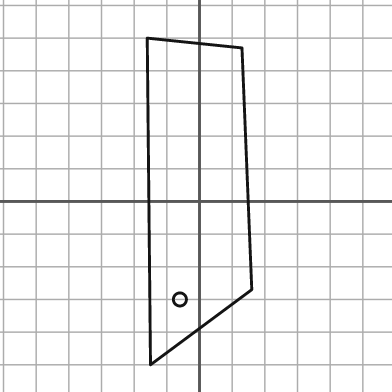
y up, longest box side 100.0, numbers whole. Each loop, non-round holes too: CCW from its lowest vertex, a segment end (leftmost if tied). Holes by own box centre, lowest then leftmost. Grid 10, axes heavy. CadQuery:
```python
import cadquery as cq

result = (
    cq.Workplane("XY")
    .moveTo(-15.0, -50.0)
    .lineTo(16.0, -27.0)
    .lineTo(13.0, 47.0)
    .lineTo(-16.0, 50.0)
    .close()
    .moveTo(-6.0, -30.0)
    .circle(2.0)
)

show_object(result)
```